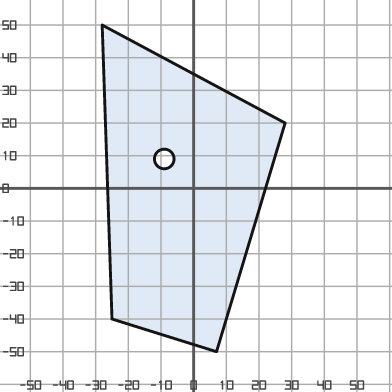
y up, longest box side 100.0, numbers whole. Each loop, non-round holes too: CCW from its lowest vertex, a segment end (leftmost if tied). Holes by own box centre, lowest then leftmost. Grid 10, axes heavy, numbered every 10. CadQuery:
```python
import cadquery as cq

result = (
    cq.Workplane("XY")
    .moveTo(7.0, -50.0)
    .lineTo(28.0, 20.0)
    .lineTo(-28.0, 50.0)
    .lineTo(-25.0, -40.0)
    .close()
    .moveTo(-9.0, 9.0)
    .circle(3.0)
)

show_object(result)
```